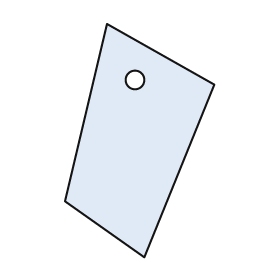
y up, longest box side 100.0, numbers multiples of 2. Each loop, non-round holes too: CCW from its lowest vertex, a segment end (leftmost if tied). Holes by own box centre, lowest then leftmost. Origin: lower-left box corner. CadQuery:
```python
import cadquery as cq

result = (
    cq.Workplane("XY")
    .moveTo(34.0, 0.0)
    .lineTo(64.0, 74.0)
    .lineTo(18.0, 100.0)
    .lineTo(0.0, 24.0)
    .close()
    .moveTo(30.0, 76.0)
    .circle(4.0)
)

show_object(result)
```